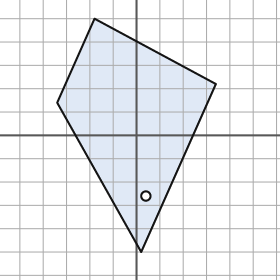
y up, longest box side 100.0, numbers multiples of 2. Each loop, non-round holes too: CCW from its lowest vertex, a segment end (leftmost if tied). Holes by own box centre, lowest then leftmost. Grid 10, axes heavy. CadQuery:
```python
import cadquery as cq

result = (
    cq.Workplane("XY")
    .moveTo(2.0, -50.0)
    .lineTo(34.0, 22.0)
    .lineTo(-18.0, 50.0)
    .lineTo(-34.0, 14.0)
    .close()
    .moveTo(4.0, -26.0)
    .circle(2.0)
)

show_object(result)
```